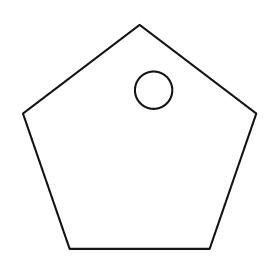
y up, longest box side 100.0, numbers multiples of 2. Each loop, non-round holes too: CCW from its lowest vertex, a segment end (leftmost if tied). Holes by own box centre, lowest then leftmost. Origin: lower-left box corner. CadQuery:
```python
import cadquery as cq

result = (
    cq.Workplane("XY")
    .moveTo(20.0, 0.0)
    .lineTo(80.0, 0.0)
    .lineTo(100.0, 58.0)
    .lineTo(50.0, 96.0)
    .lineTo(0.0, 58.0)
    .close()
    .moveTo(56.0, 68.0)
    .circle(8.0)
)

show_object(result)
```